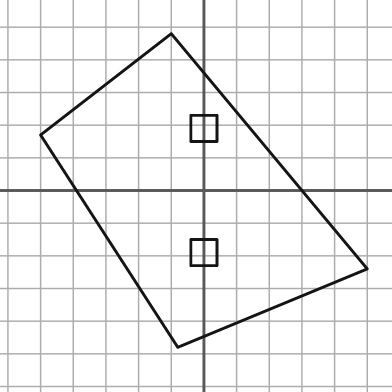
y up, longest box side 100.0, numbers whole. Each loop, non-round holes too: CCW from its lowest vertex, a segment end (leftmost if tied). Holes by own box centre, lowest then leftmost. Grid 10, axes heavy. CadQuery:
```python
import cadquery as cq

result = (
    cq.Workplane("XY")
    .moveTo(-8.0, -48.0)
    .lineTo(50.0, -24.0)
    .lineTo(-10.0, 48.0)
    .lineTo(-50.0, 17.0)
    .close()
    .moveTo(-4.0, -23.0)
    .lineTo(4.0, -23.0)
    .lineTo(4.0, -15.0)
    .lineTo(-4.0, -15.0)
    .close()
    .moveTo(-4.0, 15.0)
    .lineTo(4.0, 15.0)
    .lineTo(4.0, 23.0)
    .lineTo(-4.0, 23.0)
    .close()
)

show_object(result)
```